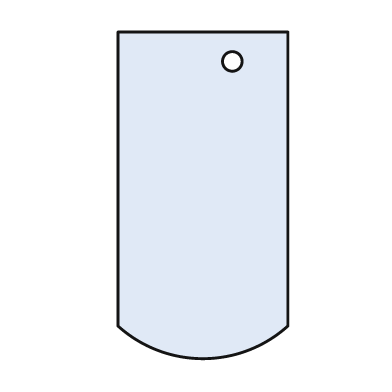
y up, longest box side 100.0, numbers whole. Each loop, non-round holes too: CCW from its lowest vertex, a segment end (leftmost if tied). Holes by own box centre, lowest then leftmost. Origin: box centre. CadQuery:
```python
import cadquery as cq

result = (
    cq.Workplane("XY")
    .moveTo(-26.0, -40.0)
    .threePointArc((0.0, -50.0), (26.0, -40.0))
    .lineTo(26.0, 50.0)
    .lineTo(-26.0, 50.0)
    .close()
    .moveTo(9.0, 41.0)
    .circle(3.0)
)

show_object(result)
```